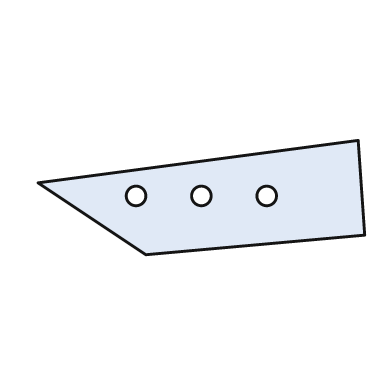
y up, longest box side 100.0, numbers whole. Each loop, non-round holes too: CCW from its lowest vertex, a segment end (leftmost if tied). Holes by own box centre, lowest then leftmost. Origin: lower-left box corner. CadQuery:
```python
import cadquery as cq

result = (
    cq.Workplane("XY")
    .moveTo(33.0, 0.0)
    .lineTo(100.0, 6.0)
    .lineTo(98.0, 35.0)
    .lineTo(0.0, 22.0)
    .close()
    .moveTo(30.0, 18.0)
    .circle(3.0)
    .moveTo(50.0, 18.0)
    .circle(3.0)
    .moveTo(70.0, 18.0)
    .circle(3.0)
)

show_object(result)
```